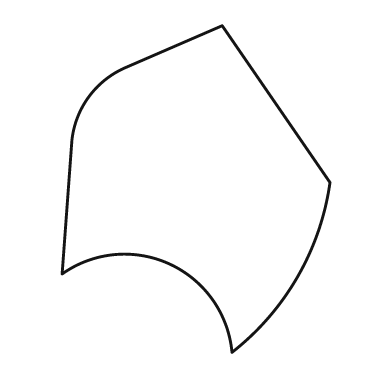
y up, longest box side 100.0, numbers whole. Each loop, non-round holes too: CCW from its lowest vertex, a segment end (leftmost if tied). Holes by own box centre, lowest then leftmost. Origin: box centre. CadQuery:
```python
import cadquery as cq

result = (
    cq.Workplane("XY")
    .moveTo(11.0, -50.0)
    .threePointArc((31.0, -27.0), (41.0, 2.0))
    .lineTo(8.0, 50.0)
    .lineTo(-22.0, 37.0)
    .threePointArc((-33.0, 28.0), (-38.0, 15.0))
    .lineTo(-41.0, -26.0)
    .threePointArc((-8.0, -23.0), (11.0, -50.0))
    .close()
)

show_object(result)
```